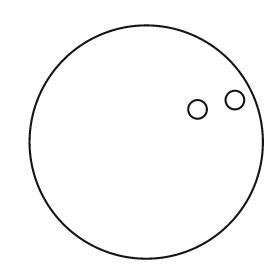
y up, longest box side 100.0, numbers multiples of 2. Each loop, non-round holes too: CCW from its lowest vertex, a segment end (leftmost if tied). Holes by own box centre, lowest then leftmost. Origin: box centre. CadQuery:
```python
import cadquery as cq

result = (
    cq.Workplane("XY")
    .moveTo(0.0, 0.0)
    .circle(50.0)
    .moveTo(22.0, 14.0)
    .circle(4.0)
    .moveTo(38.0, 18.0)
    .circle(4.0)
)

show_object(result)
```